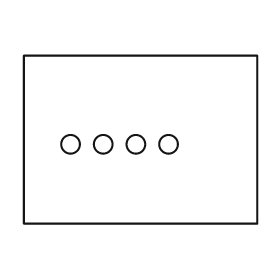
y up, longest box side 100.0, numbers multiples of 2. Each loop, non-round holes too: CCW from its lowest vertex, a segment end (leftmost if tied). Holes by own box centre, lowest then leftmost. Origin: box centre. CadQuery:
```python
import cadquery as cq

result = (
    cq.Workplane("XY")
    .moveTo(-50.0, -36.0)
    .lineTo(50.0, -36.0)
    .lineTo(50.0, 36.0)
    .lineTo(-50.0, 36.0)
    .close()
    .moveTo(-30.0, -2.0)
    .circle(4.0)
    .moveTo(-16.0, -2.0)
    .circle(4.0)
    .moveTo(-2.0, -2.0)
    .circle(4.0)
    .moveTo(12.0, -2.0)
    .circle(4.0)
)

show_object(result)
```